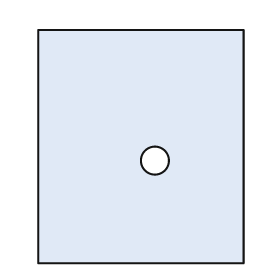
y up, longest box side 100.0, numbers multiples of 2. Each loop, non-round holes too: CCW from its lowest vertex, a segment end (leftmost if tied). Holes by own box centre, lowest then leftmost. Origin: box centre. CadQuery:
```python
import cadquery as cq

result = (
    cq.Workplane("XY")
    .moveTo(-44.0, -50.0)
    .lineTo(44.0, -50.0)
    .lineTo(44.0, 50.0)
    .lineTo(-44.0, 50.0)
    .close()
    .moveTo(6.0, -6.0)
    .circle(6.0)
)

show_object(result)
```